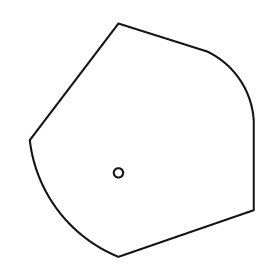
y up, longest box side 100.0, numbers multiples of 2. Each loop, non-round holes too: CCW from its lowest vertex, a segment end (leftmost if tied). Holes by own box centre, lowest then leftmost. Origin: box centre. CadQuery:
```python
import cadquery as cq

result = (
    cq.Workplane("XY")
    .moveTo(-10.0, -50.0)
    .lineTo(48.0, -30.0)
    .lineTo(48.0, 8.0)
    .threePointArc((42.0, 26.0), (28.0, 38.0))
    .lineTo(-10.0, 50.0)
    .lineTo(-48.0, 0.0)
    .threePointArc((-36.0, -30.0), (-10.0, -50.0))
    .close()
    .moveTo(-10.0, -14.0)
    .circle(2.0)
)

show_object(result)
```